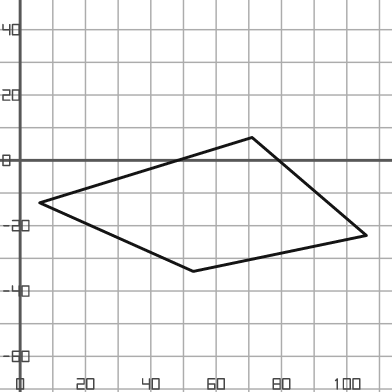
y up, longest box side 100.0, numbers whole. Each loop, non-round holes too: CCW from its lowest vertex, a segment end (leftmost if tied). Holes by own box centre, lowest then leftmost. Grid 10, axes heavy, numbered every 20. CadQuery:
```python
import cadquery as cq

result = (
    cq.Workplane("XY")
    .moveTo(53.0, -34.0)
    .lineTo(106.0, -23.0)
    .lineTo(71.0, 7.0)
    .lineTo(6.0, -13.0)
    .close()
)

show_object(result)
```